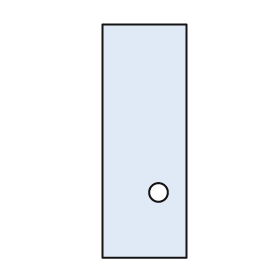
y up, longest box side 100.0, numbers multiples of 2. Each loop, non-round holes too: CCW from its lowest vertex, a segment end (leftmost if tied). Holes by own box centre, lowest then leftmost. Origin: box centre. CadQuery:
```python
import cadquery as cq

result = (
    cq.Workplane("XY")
    .moveTo(-18.0, -50.0)
    .lineTo(18.0, -50.0)
    .lineTo(18.0, 50.0)
    .lineTo(-18.0, 50.0)
    .close()
    .moveTo(6.0, -22.0)
    .circle(4.0)
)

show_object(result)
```